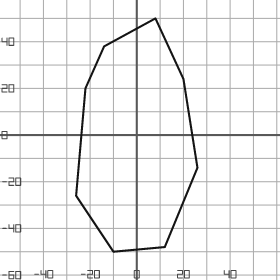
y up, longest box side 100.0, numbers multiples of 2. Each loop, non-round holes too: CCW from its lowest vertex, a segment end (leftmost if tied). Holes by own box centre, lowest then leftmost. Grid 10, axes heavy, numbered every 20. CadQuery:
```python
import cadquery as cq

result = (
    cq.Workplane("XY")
    .moveTo(-10.0, -50.0)
    .lineTo(12.0, -48.0)
    .lineTo(26.0, -14.0)
    .lineTo(20.0, 24.0)
    .lineTo(8.0, 50.0)
    .lineTo(-14.0, 38.0)
    .lineTo(-22.0, 20.0)
    .lineTo(-26.0, -26.0)
    .close()
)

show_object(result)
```